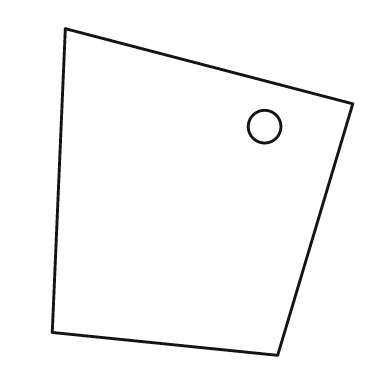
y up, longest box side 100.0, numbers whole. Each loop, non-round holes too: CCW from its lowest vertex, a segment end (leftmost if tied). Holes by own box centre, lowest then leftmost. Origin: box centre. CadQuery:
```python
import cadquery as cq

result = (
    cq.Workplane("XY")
    .moveTo(23.0, -50.0)
    .lineTo(46.0, 27.0)
    .lineTo(-42.0, 50.0)
    .lineTo(-46.0, -43.0)
    .close()
    .moveTo(19.0, 20.0)
    .circle(5.0)
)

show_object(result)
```